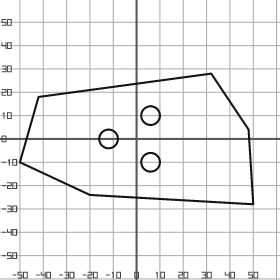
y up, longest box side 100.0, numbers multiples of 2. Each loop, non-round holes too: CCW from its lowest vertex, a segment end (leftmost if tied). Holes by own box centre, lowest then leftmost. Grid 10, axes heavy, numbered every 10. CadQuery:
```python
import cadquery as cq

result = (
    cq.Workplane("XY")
    .moveTo(50.0, -28.0)
    .lineTo(48.0, 4.0)
    .lineTo(32.0, 28.0)
    .lineTo(-42.0, 18.0)
    .lineTo(-50.0, -10.0)
    .lineTo(-20.0, -24.0)
    .close()
    .moveTo(6.0, -10.0)
    .circle(4.0)
    .moveTo(-12.0, 0.0)
    .circle(4.0)
    .moveTo(6.0, 10.0)
    .circle(4.0)
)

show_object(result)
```